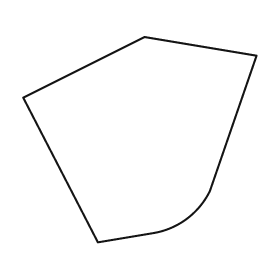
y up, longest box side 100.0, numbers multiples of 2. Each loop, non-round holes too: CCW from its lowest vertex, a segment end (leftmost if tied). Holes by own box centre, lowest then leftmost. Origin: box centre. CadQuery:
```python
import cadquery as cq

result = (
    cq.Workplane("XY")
    .moveTo(-18.0, -44.0)
    .lineTo(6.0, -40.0)
    .threePointArc((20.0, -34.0), (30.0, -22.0))
    .lineTo(50.0, 36.0)
    .lineTo(2.0, 44.0)
    .lineTo(-50.0, 18.0)
    .close()
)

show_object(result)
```